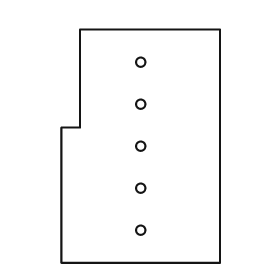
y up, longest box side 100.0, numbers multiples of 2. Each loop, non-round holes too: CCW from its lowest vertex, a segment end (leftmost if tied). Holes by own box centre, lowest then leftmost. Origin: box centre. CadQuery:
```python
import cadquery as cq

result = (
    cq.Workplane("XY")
    .moveTo(-34.0, -50.0)
    .lineTo(34.0, -50.0)
    .lineTo(34.0, 50.0)
    .lineTo(-26.0, 50.0)
    .lineTo(-26.0, 8.0)
    .lineTo(-34.0, 8.0)
    .close()
    .moveTo(0.0, -36.0)
    .circle(2.0)
    .moveTo(0.0, -18.0)
    .circle(2.0)
    .moveTo(0.0, 0.0)
    .circle(2.0)
    .moveTo(0.0, 18.0)
    .circle(2.0)
    .moveTo(0.0, 36.0)
    .circle(2.0)
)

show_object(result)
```